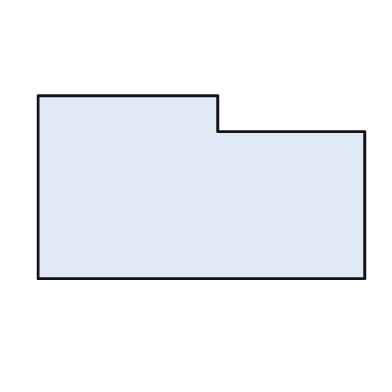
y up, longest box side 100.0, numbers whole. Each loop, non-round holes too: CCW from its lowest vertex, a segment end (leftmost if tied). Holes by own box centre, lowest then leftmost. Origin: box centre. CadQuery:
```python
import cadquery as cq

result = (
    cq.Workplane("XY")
    .moveTo(-50.0, -28.0)
    .lineTo(50.0, -28.0)
    .lineTo(50.0, 17.0)
    .lineTo(5.0, 17.0)
    .lineTo(5.0, 28.0)
    .lineTo(-50.0, 28.0)
    .close()
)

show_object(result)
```